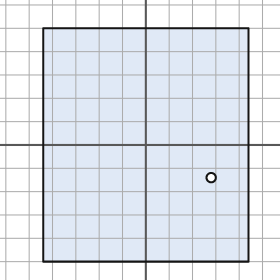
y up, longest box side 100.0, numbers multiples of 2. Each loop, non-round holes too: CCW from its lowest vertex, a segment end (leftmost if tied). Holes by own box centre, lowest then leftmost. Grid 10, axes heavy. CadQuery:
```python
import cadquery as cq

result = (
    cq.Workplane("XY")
    .moveTo(-44.0, -50.0)
    .lineTo(44.0, -50.0)
    .lineTo(44.0, 50.0)
    .lineTo(-44.0, 50.0)
    .close()
    .moveTo(28.0, -14.0)
    .circle(2.0)
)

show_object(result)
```